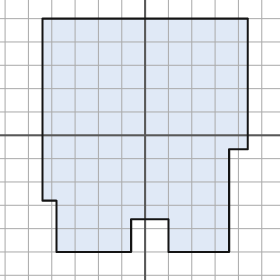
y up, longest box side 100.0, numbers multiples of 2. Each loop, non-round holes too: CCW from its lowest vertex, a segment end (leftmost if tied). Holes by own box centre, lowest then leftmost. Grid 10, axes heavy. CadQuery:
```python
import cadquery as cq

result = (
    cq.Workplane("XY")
    .moveTo(-38.0, -50.0)
    .lineTo(-6.0, -50.0)
    .lineTo(-6.0, -36.0)
    .lineTo(10.0, -36.0)
    .lineTo(10.0, -50.0)
    .lineTo(36.0, -50.0)
    .lineTo(36.0, -6.0)
    .lineTo(44.0, -6.0)
    .lineTo(44.0, 50.0)
    .lineTo(-44.0, 50.0)
    .lineTo(-44.0, -28.0)
    .lineTo(-38.0, -28.0)
    .close()
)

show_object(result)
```